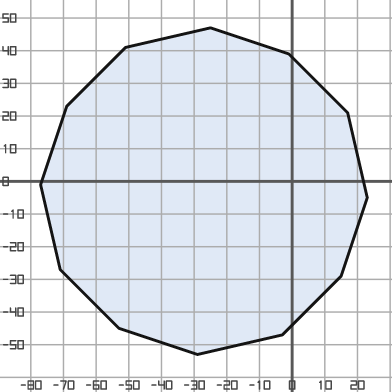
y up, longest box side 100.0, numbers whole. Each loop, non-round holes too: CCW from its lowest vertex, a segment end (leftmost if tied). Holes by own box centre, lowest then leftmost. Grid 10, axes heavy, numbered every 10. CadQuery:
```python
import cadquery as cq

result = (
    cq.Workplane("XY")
    .moveTo(-29.0, -53.0)
    .lineTo(-3.0, -47.0)
    .lineTo(15.0, -29.0)
    .lineTo(23.0, -5.0)
    .lineTo(17.0, 21.0)
    .lineTo(-1.0, 39.0)
    .lineTo(-25.0, 47.0)
    .lineTo(-51.0, 41.0)
    .lineTo(-69.0, 23.0)
    .lineTo(-77.0, -1.0)
    .lineTo(-71.0, -27.0)
    .lineTo(-53.0, -45.0)
    .close()
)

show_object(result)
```